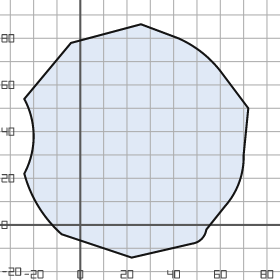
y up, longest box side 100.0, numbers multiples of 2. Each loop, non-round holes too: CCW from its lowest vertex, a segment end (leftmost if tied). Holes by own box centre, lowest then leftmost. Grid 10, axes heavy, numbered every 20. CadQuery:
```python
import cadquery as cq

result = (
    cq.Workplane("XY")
    .moveTo(22.0, -14.0)
    .lineTo(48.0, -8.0)
    .threePointArc((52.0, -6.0), (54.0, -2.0))
    .lineTo(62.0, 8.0)
    .threePointArc((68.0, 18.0), (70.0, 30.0))
    .lineTo(72.0, 50.0)
    .lineTo(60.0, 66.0)
    .threePointArc((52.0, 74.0), (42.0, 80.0))
    .lineTo(26.0, 86.0)
    .lineTo(-4.0, 78.0)
    .lineTo(-24.0, 54.0)
    .threePointArc((-20.0, 38.0), (-24.0, 22.0))
    .threePointArc((-18.0, 8.0), (-8.0, -4.0))
    .close()
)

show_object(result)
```